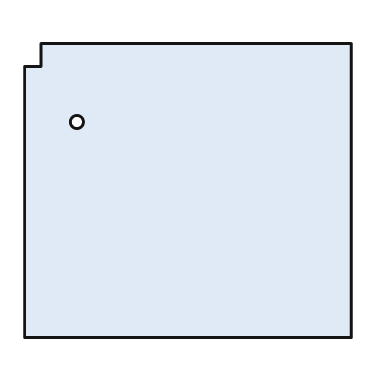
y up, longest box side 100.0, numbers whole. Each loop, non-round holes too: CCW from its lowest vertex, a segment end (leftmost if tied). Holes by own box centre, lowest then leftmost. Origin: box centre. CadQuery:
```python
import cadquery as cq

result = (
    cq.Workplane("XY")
    .moveTo(-50.0, -45.0)
    .lineTo(50.0, -45.0)
    .lineTo(50.0, 45.0)
    .lineTo(-45.0, 45.0)
    .lineTo(-45.0, 38.0)
    .lineTo(-50.0, 38.0)
    .close()
    .moveTo(-34.0, 21.0)
    .circle(2.0)
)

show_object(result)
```